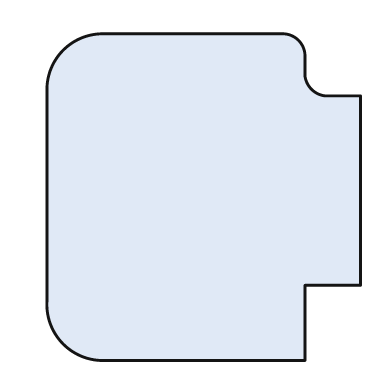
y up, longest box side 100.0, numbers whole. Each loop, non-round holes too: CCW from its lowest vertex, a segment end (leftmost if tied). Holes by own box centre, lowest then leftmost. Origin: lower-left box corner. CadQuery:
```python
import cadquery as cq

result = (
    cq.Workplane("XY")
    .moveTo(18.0, 0.0)
    .lineTo(79.0, 0.0)
    .lineTo(79.0, 23.0)
    .lineTo(96.0, 23.0)
    .lineTo(96.0, 81.0)
    .lineTo(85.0, 81.0)
    .threePointArc((81.0, 83.0), (79.0, 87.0))
    .lineTo(79.0, 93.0)
    .threePointArc((77.0, 98.0), (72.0, 100.0))
    .lineTo(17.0, 100.0)
    .threePointArc((5.0, 95.0), (0.0, 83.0))
    .lineTo(0.0, 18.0)
    .threePointArc((5.0, 5.0), (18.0, 0.0))
    .close()
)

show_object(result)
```